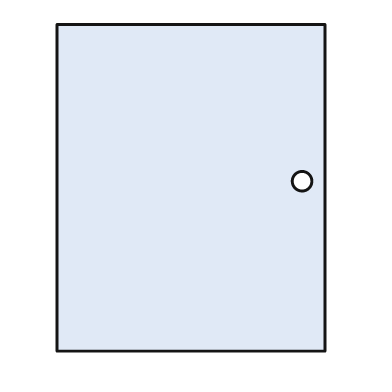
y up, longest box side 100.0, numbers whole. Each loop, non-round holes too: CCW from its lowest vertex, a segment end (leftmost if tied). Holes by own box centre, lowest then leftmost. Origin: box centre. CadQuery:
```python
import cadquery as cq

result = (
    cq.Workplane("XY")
    .moveTo(-41.0, -50.0)
    .lineTo(41.0, -50.0)
    .lineTo(41.0, 50.0)
    .lineTo(-41.0, 50.0)
    .close()
    .moveTo(34.0, 2.0)
    .circle(3.0)
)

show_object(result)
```